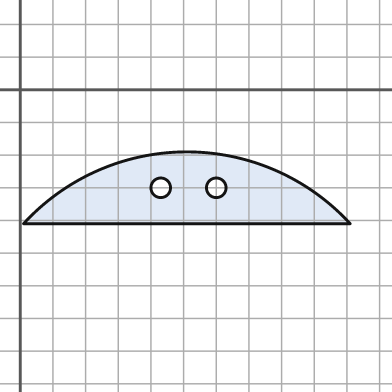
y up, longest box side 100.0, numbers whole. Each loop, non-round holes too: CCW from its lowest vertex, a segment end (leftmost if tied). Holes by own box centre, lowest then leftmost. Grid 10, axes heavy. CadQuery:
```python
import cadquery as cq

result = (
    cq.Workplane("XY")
    .moveTo(1.0, -41.0)
    .lineTo(101.0, -41.0)
    .threePointArc((51.0, -19.0), (1.0, -41.0))
    .close()
    .moveTo(43.0, -30.0)
    .circle(3.0)
    .moveTo(60.0, -30.0)
    .circle(3.0)
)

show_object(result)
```